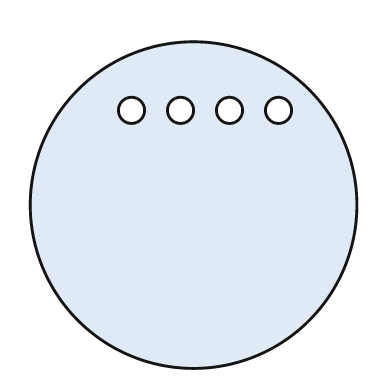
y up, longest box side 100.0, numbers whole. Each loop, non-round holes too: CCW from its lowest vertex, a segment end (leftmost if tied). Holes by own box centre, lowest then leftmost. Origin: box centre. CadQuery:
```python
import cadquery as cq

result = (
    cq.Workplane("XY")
    .moveTo(0.0, 0.0)
    .circle(50.0)
    .moveTo(-19.0, 29.0)
    .circle(4.0)
    .moveTo(-4.0, 29.0)
    .circle(4.0)
    .moveTo(11.0, 29.0)
    .circle(4.0)
    .moveTo(26.0, 29.0)
    .circle(4.0)
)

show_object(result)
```